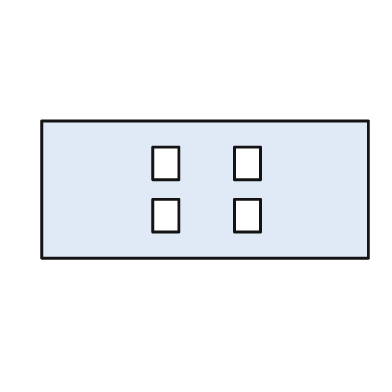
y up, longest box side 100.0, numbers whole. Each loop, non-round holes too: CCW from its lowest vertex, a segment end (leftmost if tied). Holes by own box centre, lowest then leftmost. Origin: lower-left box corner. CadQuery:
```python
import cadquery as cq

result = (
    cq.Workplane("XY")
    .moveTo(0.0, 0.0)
    .lineTo(100.0, 0.0)
    .lineTo(100.0, 42.0)
    .lineTo(0.0, 42.0)
    .close()
    .moveTo(34.0, 8.0)
    .lineTo(42.0, 8.0)
    .lineTo(42.0, 18.0)
    .lineTo(34.0, 18.0)
    .close()
    .moveTo(59.0, 8.0)
    .lineTo(67.0, 8.0)
    .lineTo(67.0, 18.0)
    .lineTo(59.0, 18.0)
    .close()
    .moveTo(34.0, 24.0)
    .lineTo(42.0, 24.0)
    .lineTo(42.0, 34.0)
    .lineTo(34.0, 34.0)
    .close()
    .moveTo(59.0, 24.0)
    .lineTo(67.0, 24.0)
    .lineTo(67.0, 34.0)
    .lineTo(59.0, 34.0)
    .close()
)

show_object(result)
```